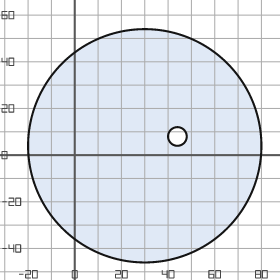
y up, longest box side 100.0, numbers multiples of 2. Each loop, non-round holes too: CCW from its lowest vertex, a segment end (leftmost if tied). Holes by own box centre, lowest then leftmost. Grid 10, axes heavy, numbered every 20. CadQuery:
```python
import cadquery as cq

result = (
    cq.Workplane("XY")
    .moveTo(30.0, 4.0)
    .circle(50.0)
    .moveTo(44.0, 8.0)
    .circle(4.0)
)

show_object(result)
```